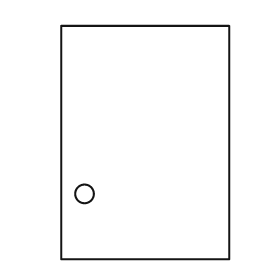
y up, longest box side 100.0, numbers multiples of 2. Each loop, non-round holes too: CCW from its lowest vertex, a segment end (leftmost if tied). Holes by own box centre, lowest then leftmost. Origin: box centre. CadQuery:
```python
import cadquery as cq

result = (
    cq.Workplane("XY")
    .moveTo(-36.0, -50.0)
    .lineTo(36.0, -50.0)
    .lineTo(36.0, 50.0)
    .lineTo(-36.0, 50.0)
    .close()
    .moveTo(-26.0, -22.0)
    .circle(4.0)
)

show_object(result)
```